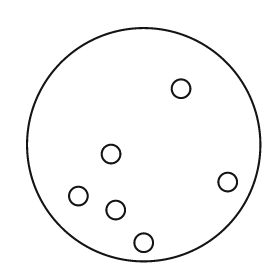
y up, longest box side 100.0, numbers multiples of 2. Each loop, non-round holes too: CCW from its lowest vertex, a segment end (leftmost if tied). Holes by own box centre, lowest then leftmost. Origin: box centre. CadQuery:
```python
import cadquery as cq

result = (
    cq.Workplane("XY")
    .moveTo(0.0, 0.0)
    .circle(50.0)
    .moveTo(0.0, -42.0)
    .circle(4.0)
    .moveTo(-12.0, -28.0)
    .circle(4.0)
    .moveTo(-28.0, -22.0)
    .circle(4.0)
    .moveTo(36.0, -16.0)
    .circle(4.0)
    .moveTo(-14.0, -4.0)
    .circle(4.0)
    .moveTo(16.0, 24.0)
    .circle(4.0)
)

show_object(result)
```